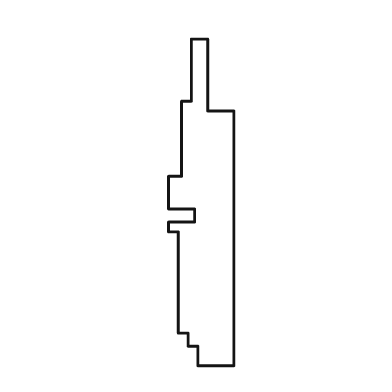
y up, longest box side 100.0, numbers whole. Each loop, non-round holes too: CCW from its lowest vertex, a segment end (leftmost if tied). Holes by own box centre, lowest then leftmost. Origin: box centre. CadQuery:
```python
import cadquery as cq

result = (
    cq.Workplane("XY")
    .moveTo(-1.0, -50.0)
    .lineTo(10.0, -50.0)
    .lineTo(10.0, 28.0)
    .lineTo(2.0, 28.0)
    .lineTo(2.0, 50.0)
    .lineTo(-3.0, 50.0)
    .lineTo(-3.0, 31.0)
    .lineTo(-6.0, 31.0)
    .lineTo(-6.0, 8.0)
    .lineTo(-10.0, 8.0)
    .lineTo(-10.0, -2.0)
    .lineTo(-2.0, -2.0)
    .lineTo(-2.0, -6.0)
    .lineTo(-10.0, -6.0)
    .lineTo(-10.0, -9.0)
    .lineTo(-7.0, -9.0)
    .lineTo(-7.0, -40.0)
    .lineTo(-4.0, -40.0)
    .lineTo(-4.0, -44.0)
    .lineTo(-1.0, -44.0)
    .close()
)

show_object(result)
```